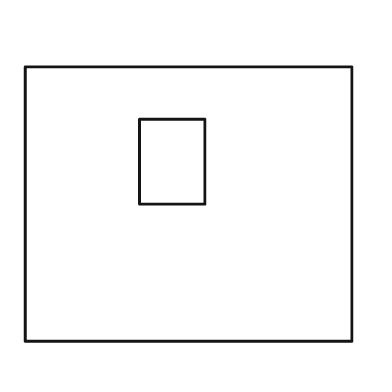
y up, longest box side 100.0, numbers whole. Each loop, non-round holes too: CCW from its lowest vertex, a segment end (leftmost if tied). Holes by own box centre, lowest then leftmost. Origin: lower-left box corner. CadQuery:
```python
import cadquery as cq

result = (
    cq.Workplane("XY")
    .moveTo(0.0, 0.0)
    .lineTo(100.0, 0.0)
    .lineTo(100.0, 84.0)
    .lineTo(0.0, 84.0)
    .close()
    .moveTo(35.0, 42.0)
    .lineTo(55.0, 42.0)
    .lineTo(55.0, 68.0)
    .lineTo(35.0, 68.0)
    .close()
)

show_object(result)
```